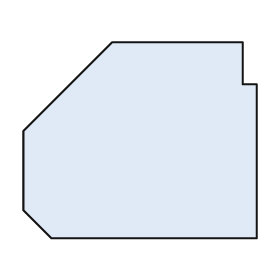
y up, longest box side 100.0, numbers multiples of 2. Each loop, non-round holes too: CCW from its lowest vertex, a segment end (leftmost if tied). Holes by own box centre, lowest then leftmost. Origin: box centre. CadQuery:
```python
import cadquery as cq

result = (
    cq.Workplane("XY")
    .moveTo(-38.0, -42.0)
    .lineTo(50.0, -42.0)
    .lineTo(50.0, 24.0)
    .lineTo(44.0, 24.0)
    .lineTo(44.0, 42.0)
    .lineTo(-12.0, 42.0)
    .lineTo(-50.0, 4.0)
    .lineTo(-50.0, -30.0)
    .close()
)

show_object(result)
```